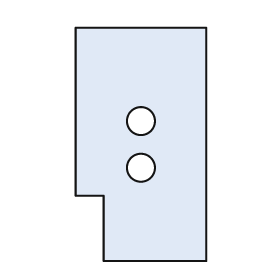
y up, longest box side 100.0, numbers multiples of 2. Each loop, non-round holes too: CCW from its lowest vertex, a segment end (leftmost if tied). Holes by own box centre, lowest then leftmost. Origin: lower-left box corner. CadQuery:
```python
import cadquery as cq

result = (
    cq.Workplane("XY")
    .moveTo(12.0, 0.0)
    .lineTo(56.0, 0.0)
    .lineTo(56.0, 100.0)
    .lineTo(0.0, 100.0)
    .lineTo(0.0, 28.0)
    .lineTo(12.0, 28.0)
    .close()
    .moveTo(28.0, 40.0)
    .circle(6.0)
    .moveTo(28.0, 60.0)
    .circle(6.0)
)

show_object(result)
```